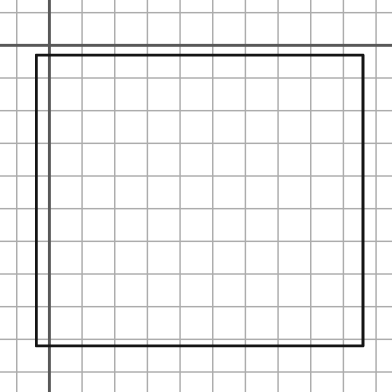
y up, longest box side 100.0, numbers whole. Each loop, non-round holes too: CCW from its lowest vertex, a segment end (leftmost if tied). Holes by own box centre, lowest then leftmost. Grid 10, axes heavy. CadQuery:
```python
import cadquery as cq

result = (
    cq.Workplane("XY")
    .moveTo(-4.0, -92.0)
    .lineTo(96.0, -92.0)
    .lineTo(96.0, -3.0)
    .lineTo(-4.0, -3.0)
    .close()
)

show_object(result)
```